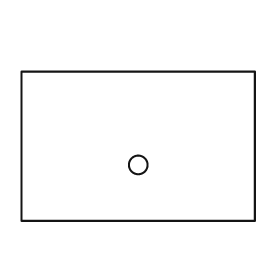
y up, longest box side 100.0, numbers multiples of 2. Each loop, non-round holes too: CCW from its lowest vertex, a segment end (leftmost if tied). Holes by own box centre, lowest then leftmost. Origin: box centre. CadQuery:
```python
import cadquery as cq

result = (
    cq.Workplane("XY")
    .moveTo(-50.0, -32.0)
    .lineTo(50.0, -32.0)
    .lineTo(50.0, 32.0)
    .lineTo(-50.0, 32.0)
    .close()
    .moveTo(0.0, -8.0)
    .circle(4.0)
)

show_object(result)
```